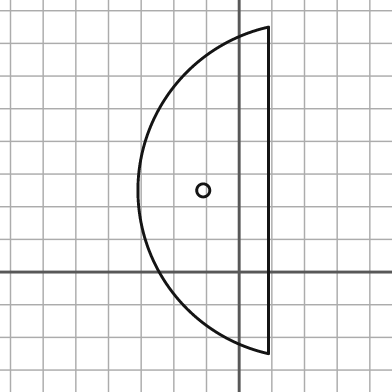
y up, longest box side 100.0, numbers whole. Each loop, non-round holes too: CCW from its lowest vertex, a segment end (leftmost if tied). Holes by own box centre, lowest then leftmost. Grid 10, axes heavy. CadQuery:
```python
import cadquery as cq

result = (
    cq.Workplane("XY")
    .moveTo(9.0, -25.0)
    .lineTo(9.0, 75.0)
    .threePointArc((-31.0, 25.0), (9.0, -25.0))
    .close()
    .moveTo(-11.0, 25.0)
    .circle(2.0)
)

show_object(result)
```